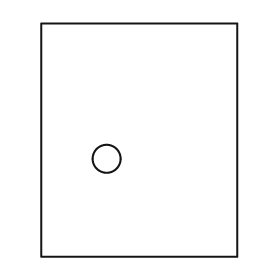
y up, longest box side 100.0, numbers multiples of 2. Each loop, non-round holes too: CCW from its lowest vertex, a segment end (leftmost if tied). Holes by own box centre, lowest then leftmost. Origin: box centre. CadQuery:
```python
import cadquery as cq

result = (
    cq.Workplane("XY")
    .moveTo(-42.0, -50.0)
    .lineTo(42.0, -50.0)
    .lineTo(42.0, 50.0)
    .lineTo(-42.0, 50.0)
    .close()
    .moveTo(-14.0, -8.0)
    .circle(6.0)
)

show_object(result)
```